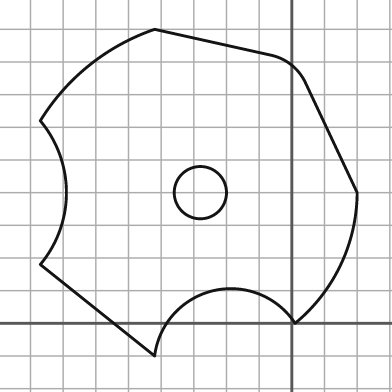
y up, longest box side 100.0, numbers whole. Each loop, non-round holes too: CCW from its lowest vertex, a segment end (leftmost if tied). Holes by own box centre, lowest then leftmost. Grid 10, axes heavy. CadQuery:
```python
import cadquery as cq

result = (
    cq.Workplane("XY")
    .moveTo(-42.0, -10.0)
    .threePointArc((-24.0, 10.0), (1.0, 0.0))
    .threePointArc((15.0, 18.0), (20.0, 40.0))
    .lineTo(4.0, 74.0)
    .threePointArc((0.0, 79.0), (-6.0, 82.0))
    .lineTo(-42.0, 90.0)
    .threePointArc((-62.0, 79.0), (-77.0, 62.0))
    .threePointArc((-69.0, 40.0), (-77.0, 18.0))
    .close()
    .moveTo(-28.0, 40.0)
    .circle(8.0)
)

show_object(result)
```